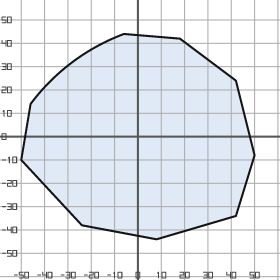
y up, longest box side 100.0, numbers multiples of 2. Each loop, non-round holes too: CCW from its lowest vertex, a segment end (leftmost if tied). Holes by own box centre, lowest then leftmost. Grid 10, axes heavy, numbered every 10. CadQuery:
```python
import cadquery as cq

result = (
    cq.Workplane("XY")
    .moveTo(8.0, -44.0)
    .lineTo(42.0, -34.0)
    .lineTo(50.0, -8.0)
    .lineTo(42.0, 24.0)
    .lineTo(18.0, 42.0)
    .lineTo(-6.0, 44.0)
    .threePointArc((-28.0, 32.0), (-46.0, 14.0))
    .lineTo(-50.0, -10.0)
    .lineTo(-24.0, -38.0)
    .close()
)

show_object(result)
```